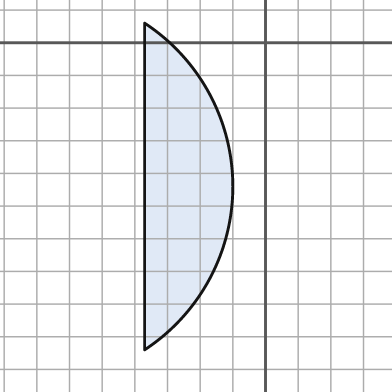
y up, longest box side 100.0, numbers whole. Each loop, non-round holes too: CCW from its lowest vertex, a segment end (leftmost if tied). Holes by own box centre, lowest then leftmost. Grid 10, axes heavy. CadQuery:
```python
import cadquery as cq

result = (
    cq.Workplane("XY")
    .moveTo(-37.0, -94.0)
    .threePointArc((-10.0, -44.0), (-37.0, 6.0))
    .close()
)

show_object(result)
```